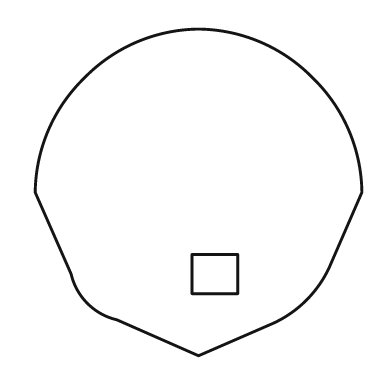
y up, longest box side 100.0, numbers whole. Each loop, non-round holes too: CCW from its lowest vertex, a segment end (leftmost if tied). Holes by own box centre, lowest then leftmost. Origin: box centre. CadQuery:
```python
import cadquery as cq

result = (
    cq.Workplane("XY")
    .moveTo(0.0, -50.0)
    .lineTo(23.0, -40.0)
    .threePointArc((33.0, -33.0), (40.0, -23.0))
    .lineTo(50.0, 0.0)
    .threePointArc((46.0, 19.0), (35.0, 35.0))
    .threePointArc((19.0, 46.0), (0.0, 50.0))
    .threePointArc((-19.0, 46.0), (-35.0, 35.0))
    .threePointArc((-46.0, 19.0), (-50.0, 0.0))
    .lineTo(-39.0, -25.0)
    .threePointArc((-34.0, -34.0), (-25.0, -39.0))
    .close()
    .moveTo(-2.0, -31.0)
    .lineTo(12.0, -31.0)
    .lineTo(12.0, -19.0)
    .lineTo(-2.0, -19.0)
    .close()
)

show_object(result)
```